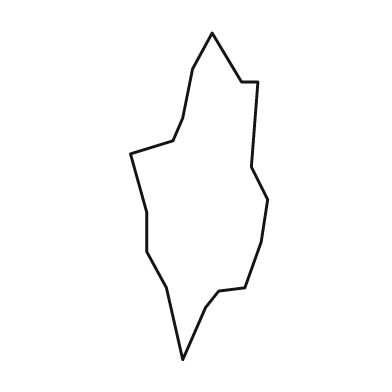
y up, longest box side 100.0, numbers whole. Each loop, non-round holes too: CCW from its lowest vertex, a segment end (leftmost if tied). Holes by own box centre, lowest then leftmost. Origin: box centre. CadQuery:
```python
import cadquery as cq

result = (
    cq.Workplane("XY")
    .moveTo(-5.0, -50.0)
    .lineTo(2.0, -34.0)
    .lineTo(6.0, -29.0)
    .lineTo(14.0, -28.0)
    .lineTo(19.0, -14.0)
    .lineTo(21.0, -1.0)
    .lineTo(16.0, 9.0)
    .lineTo(18.0, 35.0)
    .lineTo(13.0, 35.0)
    .lineTo(4.0, 50.0)
    .lineTo(-2.0, 39.0)
    .lineTo(-5.0, 24.0)
    .lineTo(-8.0, 17.0)
    .lineTo(-21.0, 13.0)
    .lineTo(-16.0, -5.0)
    .lineTo(-16.0, -17.0)
    .lineTo(-10.0, -28.0)
    .close()
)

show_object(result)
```